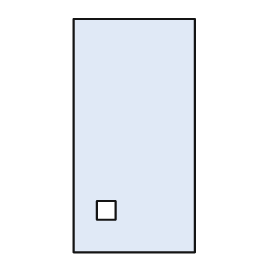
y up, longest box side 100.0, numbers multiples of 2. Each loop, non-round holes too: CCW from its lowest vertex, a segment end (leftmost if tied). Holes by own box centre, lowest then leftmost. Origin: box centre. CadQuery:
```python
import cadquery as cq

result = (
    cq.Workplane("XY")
    .moveTo(-26.0, -50.0)
    .lineTo(26.0, -50.0)
    .lineTo(26.0, 50.0)
    .lineTo(-26.0, 50.0)
    .close()
    .moveTo(-16.0, -36.0)
    .lineTo(-8.0, -36.0)
    .lineTo(-8.0, -28.0)
    .lineTo(-16.0, -28.0)
    .close()
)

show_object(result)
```